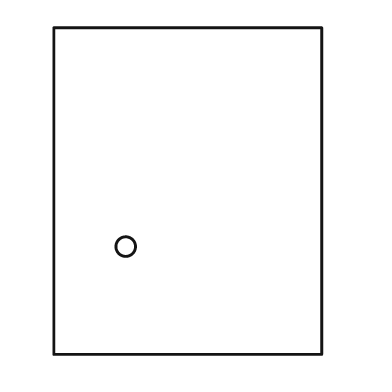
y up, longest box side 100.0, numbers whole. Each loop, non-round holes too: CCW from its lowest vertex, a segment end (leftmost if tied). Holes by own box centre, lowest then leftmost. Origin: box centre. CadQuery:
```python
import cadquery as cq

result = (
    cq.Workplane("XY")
    .moveTo(-41.0, -50.0)
    .lineTo(41.0, -50.0)
    .lineTo(41.0, 50.0)
    .lineTo(-41.0, 50.0)
    .close()
    .moveTo(-19.0, -17.0)
    .circle(3.0)
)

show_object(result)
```